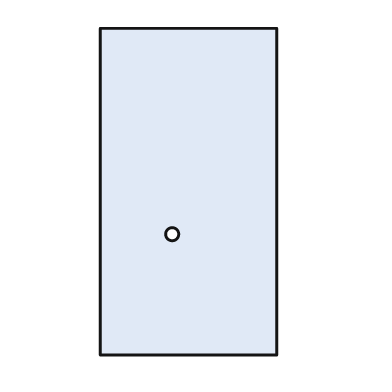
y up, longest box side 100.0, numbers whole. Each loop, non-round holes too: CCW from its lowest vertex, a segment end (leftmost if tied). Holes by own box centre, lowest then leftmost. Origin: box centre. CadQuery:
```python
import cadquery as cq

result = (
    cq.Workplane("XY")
    .moveTo(-27.0, -50.0)
    .lineTo(27.0, -50.0)
    .lineTo(27.0, 50.0)
    .lineTo(-27.0, 50.0)
    .close()
    .moveTo(-5.0, -13.0)
    .circle(2.0)
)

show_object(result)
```